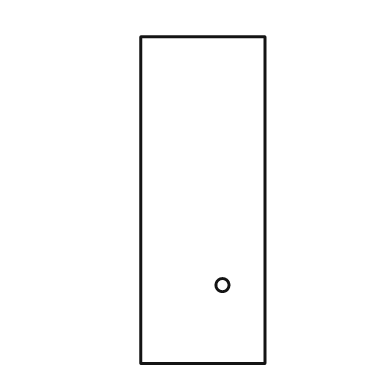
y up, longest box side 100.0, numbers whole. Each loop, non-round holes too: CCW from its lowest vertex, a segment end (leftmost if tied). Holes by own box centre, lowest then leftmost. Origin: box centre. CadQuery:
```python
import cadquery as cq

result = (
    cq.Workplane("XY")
    .moveTo(-19.0, -50.0)
    .lineTo(19.0, -50.0)
    .lineTo(19.0, 50.0)
    .lineTo(-19.0, 50.0)
    .close()
    .moveTo(6.0, -26.0)
    .circle(2.0)
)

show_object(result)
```